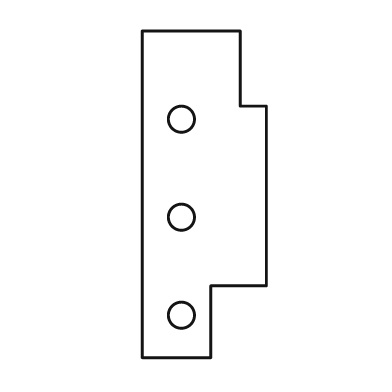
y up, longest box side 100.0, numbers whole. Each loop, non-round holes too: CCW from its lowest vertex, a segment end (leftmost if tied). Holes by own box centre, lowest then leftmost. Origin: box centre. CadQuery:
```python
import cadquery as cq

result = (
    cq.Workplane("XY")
    .moveTo(-19.0, -50.0)
    .lineTo(2.0, -50.0)
    .lineTo(2.0, -28.0)
    .lineTo(19.0, -28.0)
    .lineTo(19.0, 27.0)
    .lineTo(11.0, 27.0)
    .lineTo(11.0, 50.0)
    .lineTo(-19.0, 50.0)
    .close()
    .moveTo(-7.0, -37.0)
    .circle(4.0)
    .moveTo(-7.0, -7.0)
    .circle(4.0)
    .moveTo(-7.0, 23.0)
    .circle(4.0)
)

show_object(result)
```